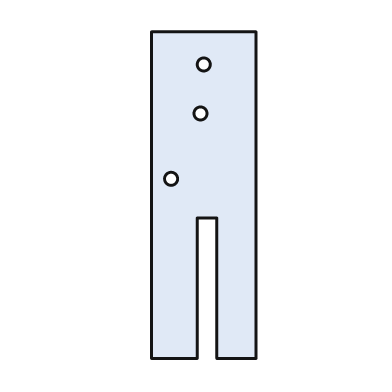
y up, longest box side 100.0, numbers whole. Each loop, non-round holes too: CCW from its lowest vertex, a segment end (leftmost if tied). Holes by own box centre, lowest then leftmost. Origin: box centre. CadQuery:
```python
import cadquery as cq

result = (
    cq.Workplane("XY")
    .moveTo(-16.0, -50.0)
    .lineTo(-2.0, -50.0)
    .lineTo(-2.0, -7.0)
    .lineTo(4.0, -7.0)
    .lineTo(4.0, -50.0)
    .lineTo(16.0, -50.0)
    .lineTo(16.0, 50.0)
    .lineTo(-16.0, 50.0)
    .close()
    .moveTo(-10.0, 5.0)
    .circle(2.0)
    .moveTo(-1.0, 25.0)
    .circle(2.0)
    .moveTo(0.0, 40.0)
    .circle(2.0)
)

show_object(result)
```